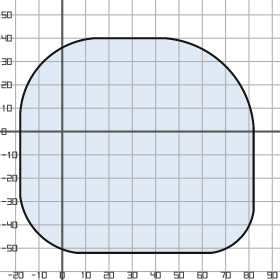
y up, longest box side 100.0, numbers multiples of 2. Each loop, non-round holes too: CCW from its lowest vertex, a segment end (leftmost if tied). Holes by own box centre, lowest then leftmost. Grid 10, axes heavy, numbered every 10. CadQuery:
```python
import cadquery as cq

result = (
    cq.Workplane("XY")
    .moveTo(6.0, -52.0)
    .lineTo(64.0, -52.0)
    .threePointArc((76.0, -46.0), (82.0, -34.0))
    .lineTo(82.0, 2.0)
    .threePointArc((70.0, 28.0), (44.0, 40.0))
    .lineTo(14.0, 40.0)
    .threePointArc((-8.0, 30.0), (-18.0, 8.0))
    .lineTo(-18.0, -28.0)
    .threePointArc((-10.0, -44.0), (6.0, -52.0))
    .close()
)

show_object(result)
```